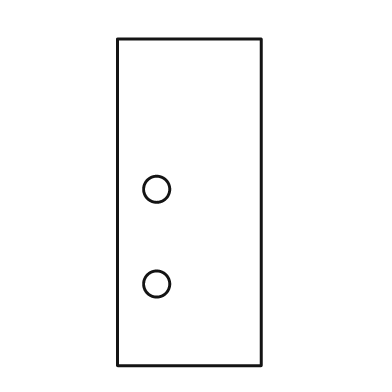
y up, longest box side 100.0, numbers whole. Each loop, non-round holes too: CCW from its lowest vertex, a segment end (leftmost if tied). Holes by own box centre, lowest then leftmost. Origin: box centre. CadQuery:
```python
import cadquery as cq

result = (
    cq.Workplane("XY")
    .moveTo(-22.0, -50.0)
    .lineTo(22.0, -50.0)
    .lineTo(22.0, 50.0)
    .lineTo(-22.0, 50.0)
    .close()
    .moveTo(-10.0, -25.0)
    .circle(4.0)
    .moveTo(-10.0, 4.0)
    .circle(4.0)
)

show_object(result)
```